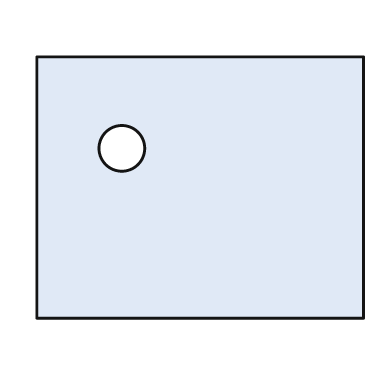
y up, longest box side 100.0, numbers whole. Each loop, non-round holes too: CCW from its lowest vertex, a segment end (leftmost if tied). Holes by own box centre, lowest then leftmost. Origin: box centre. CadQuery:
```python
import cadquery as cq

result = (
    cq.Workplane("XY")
    .moveTo(-50.0, -40.0)
    .lineTo(50.0, -40.0)
    .lineTo(50.0, 40.0)
    .lineTo(-50.0, 40.0)
    .close()
    .moveTo(-24.0, 12.0)
    .circle(7.0)
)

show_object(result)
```